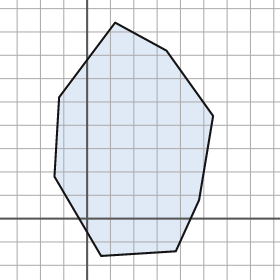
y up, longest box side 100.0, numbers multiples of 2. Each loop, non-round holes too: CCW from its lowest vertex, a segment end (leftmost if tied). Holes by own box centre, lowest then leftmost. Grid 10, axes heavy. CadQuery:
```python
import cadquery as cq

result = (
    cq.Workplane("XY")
    .moveTo(6.0, -16.0)
    .lineTo(38.0, -14.0)
    .lineTo(48.0, 8.0)
    .lineTo(54.0, 44.0)
    .lineTo(34.0, 72.0)
    .lineTo(12.0, 84.0)
    .lineTo(-12.0, 52.0)
    .lineTo(-14.0, 18.0)
    .close()
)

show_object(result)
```